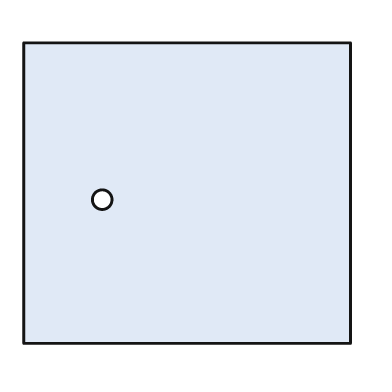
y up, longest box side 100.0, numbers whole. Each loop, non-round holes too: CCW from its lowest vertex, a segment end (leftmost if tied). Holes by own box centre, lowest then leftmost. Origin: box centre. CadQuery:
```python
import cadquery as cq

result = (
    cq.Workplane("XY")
    .moveTo(-50.0, -46.0)
    .lineTo(50.0, -46.0)
    .lineTo(50.0, 46.0)
    .lineTo(-50.0, 46.0)
    .close()
    .moveTo(-26.0, -2.0)
    .circle(3.0)
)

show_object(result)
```